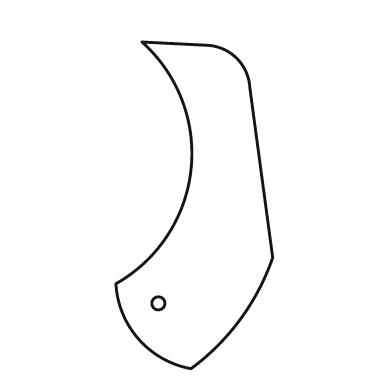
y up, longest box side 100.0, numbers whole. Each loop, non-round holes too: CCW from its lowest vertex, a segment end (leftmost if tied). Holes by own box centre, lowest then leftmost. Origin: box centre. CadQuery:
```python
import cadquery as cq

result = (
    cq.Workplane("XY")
    .moveTo(-1.0, -50.0)
    .threePointArc((14.0, -35.0), (24.0, -16.0))
    .lineTo(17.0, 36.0)
    .threePointArc((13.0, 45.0), (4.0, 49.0))
    .lineTo(-16.0, 50.0)
    .threePointArc((-1.0, 11.0), (-24.0, -24.0))
    .threePointArc((-17.0, -41.0), (-1.0, -50.0))
    .close()
    .moveTo(-11.0, -30.0)
    .circle(2.0)
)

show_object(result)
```